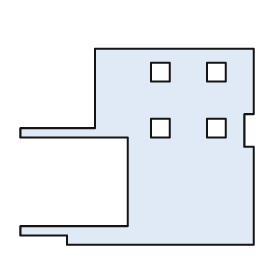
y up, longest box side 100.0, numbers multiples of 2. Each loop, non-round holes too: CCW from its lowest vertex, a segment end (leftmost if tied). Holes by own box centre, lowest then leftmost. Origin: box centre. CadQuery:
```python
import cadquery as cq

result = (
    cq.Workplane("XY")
    .moveTo(-30.0, -42.0)
    .lineTo(50.0, -42.0)
    .lineTo(50.0, 0.0)
    .lineTo(46.0, 0.0)
    .lineTo(46.0, 14.0)
    .lineTo(50.0, 14.0)
    .lineTo(50.0, 42.0)
    .lineTo(-18.0, 42.0)
    .lineTo(-18.0, 8.0)
    .lineTo(-50.0, 8.0)
    .lineTo(-50.0, 4.0)
    .lineTo(-4.0, 4.0)
    .lineTo(-4.0, -34.0)
    .lineTo(-50.0, -34.0)
    .lineTo(-50.0, -38.0)
    .lineTo(-30.0, -38.0)
    .close()
    .moveTo(6.0, 4.0)
    .lineTo(14.0, 4.0)
    .lineTo(14.0, 12.0)
    .lineTo(6.0, 12.0)
    .close()
    .moveTo(30.0, 4.0)
    .lineTo(38.0, 4.0)
    .lineTo(38.0, 12.0)
    .lineTo(30.0, 12.0)
    .close()
    .moveTo(6.0, 28.0)
    .lineTo(14.0, 28.0)
    .lineTo(14.0, 36.0)
    .lineTo(6.0, 36.0)
    .close()
    .moveTo(30.0, 28.0)
    .lineTo(38.0, 28.0)
    .lineTo(38.0, 36.0)
    .lineTo(30.0, 36.0)
    .close()
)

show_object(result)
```